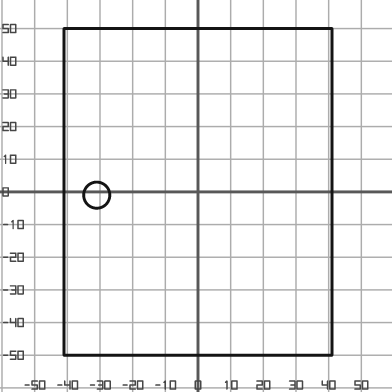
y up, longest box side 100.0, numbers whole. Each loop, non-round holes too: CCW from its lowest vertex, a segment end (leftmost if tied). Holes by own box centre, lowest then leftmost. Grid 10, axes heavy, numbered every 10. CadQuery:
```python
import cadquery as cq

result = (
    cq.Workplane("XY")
    .moveTo(-41.0, -50.0)
    .lineTo(41.0, -50.0)
    .lineTo(41.0, 50.0)
    .lineTo(-41.0, 50.0)
    .close()
    .moveTo(-31.0, -1.0)
    .circle(4.0)
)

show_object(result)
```